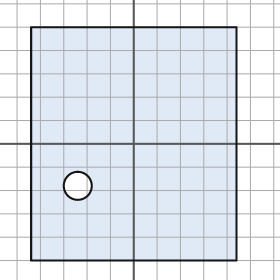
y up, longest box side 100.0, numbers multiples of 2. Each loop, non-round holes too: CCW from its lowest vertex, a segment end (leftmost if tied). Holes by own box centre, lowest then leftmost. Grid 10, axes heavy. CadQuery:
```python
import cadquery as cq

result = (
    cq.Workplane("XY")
    .moveTo(-44.0, -50.0)
    .lineTo(44.0, -50.0)
    .lineTo(44.0, 50.0)
    .lineTo(-44.0, 50.0)
    .close()
    .moveTo(-24.0, -18.0)
    .circle(6.0)
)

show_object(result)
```